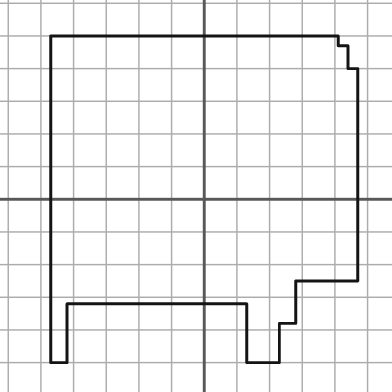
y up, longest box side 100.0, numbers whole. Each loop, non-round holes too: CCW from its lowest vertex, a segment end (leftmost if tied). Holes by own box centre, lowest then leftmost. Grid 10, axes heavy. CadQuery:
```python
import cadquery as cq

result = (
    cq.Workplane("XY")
    .moveTo(-47.0, -50.0)
    .lineTo(-42.0, -50.0)
    .lineTo(-42.0, -32.0)
    .lineTo(13.0, -32.0)
    .lineTo(13.0, -50.0)
    .lineTo(23.0, -50.0)
    .lineTo(23.0, -38.0)
    .lineTo(28.0, -38.0)
    .lineTo(28.0, -25.0)
    .lineTo(47.0, -25.0)
    .lineTo(47.0, 40.0)
    .lineTo(44.0, 40.0)
    .lineTo(44.0, 47.0)
    .lineTo(41.0, 47.0)
    .lineTo(41.0, 50.0)
    .lineTo(-47.0, 50.0)
    .close()
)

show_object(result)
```